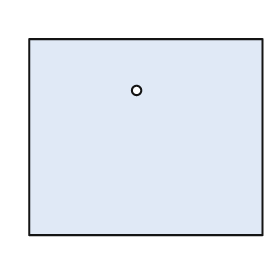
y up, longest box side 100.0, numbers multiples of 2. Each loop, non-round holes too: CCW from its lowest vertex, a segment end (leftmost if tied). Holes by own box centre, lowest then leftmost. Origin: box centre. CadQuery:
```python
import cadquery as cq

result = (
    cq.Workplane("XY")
    .moveTo(-50.0, -42.0)
    .lineTo(50.0, -42.0)
    .lineTo(50.0, 42.0)
    .lineTo(-50.0, 42.0)
    .close()
    .moveTo(-4.0, 20.0)
    .circle(2.0)
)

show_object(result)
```